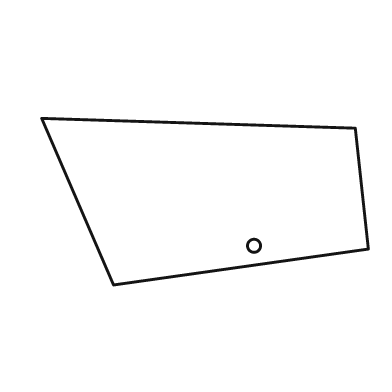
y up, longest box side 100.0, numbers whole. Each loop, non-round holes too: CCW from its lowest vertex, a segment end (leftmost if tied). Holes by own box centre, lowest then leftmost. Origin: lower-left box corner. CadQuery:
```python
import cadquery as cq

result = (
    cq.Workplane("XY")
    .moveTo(22.0, 0.0)
    .lineTo(100.0, 11.0)
    .lineTo(96.0, 48.0)
    .lineTo(0.0, 51.0)
    .close()
    .moveTo(65.0, 12.0)
    .circle(2.0)
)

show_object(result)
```